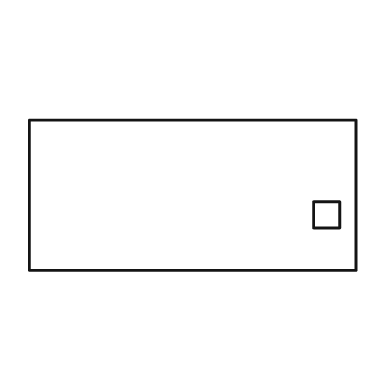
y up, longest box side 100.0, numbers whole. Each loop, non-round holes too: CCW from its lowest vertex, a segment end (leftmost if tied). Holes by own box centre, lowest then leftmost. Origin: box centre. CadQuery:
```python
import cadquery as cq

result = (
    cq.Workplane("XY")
    .moveTo(-50.0, -23.0)
    .lineTo(50.0, -23.0)
    .lineTo(50.0, 23.0)
    .lineTo(-50.0, 23.0)
    .close()
    .moveTo(37.0, -10.0)
    .lineTo(45.0, -10.0)
    .lineTo(45.0, -2.0)
    .lineTo(37.0, -2.0)
    .close()
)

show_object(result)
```